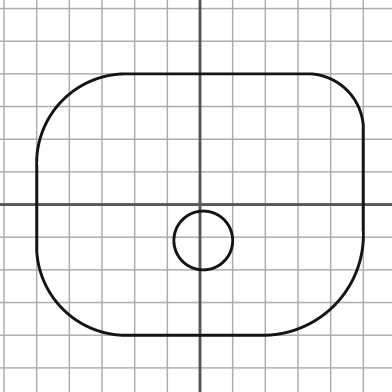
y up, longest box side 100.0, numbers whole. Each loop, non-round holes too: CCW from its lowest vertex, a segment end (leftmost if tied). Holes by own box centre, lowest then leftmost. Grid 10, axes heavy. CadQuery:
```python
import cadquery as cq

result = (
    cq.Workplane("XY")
    .moveTo(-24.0, -40.0)
    .lineTo(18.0, -40.0)
    .threePointArc((41.0, -31.0), (50.0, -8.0))
    .lineTo(50.0, 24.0)
    .threePointArc((45.0, 35.0), (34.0, 40.0))
    .lineTo(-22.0, 40.0)
    .threePointArc((-42.0, 32.0), (-50.0, 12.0))
    .lineTo(-50.0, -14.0)
    .threePointArc((-42.0, -32.0), (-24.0, -40.0))
    .close()
    .moveTo(1.0, -11.0)
    .circle(9.0)
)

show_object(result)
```